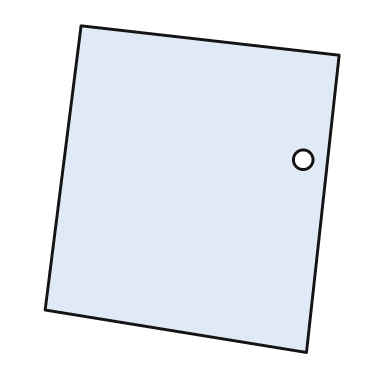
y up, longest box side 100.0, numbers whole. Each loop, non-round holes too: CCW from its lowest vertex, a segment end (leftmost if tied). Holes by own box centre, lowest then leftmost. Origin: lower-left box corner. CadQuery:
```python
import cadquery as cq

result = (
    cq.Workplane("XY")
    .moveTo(80.0, 0.0)
    .lineTo(90.0, 91.0)
    .lineTo(11.0, 100.0)
    .lineTo(0.0, 13.0)
    .close()
    .moveTo(79.0, 59.0)
    .circle(3.0)
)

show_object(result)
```